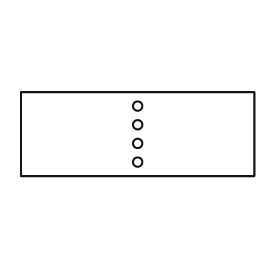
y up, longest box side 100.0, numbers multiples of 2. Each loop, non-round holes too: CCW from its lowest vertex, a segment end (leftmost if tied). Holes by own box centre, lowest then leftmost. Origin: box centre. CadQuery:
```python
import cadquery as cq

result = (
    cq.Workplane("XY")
    .moveTo(-50.0, -18.0)
    .lineTo(50.0, -18.0)
    .lineTo(50.0, 18.0)
    .lineTo(-50.0, 18.0)
    .close()
    .moveTo(0.0, -12.0)
    .circle(2.0)
    .moveTo(0.0, -4.0)
    .circle(2.0)
    .moveTo(0.0, 4.0)
    .circle(2.0)
    .moveTo(0.0, 12.0)
    .circle(2.0)
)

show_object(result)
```